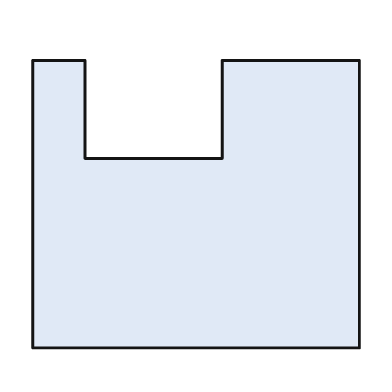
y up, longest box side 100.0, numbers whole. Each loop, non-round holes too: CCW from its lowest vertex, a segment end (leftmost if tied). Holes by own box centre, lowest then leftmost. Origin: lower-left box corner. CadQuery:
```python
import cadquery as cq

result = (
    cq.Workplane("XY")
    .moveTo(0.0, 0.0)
    .lineTo(100.0, 0.0)
    .lineTo(100.0, 88.0)
    .lineTo(58.0, 88.0)
    .lineTo(58.0, 58.0)
    .lineTo(16.0, 58.0)
    .lineTo(16.0, 88.0)
    .lineTo(0.0, 88.0)
    .close()
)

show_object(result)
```